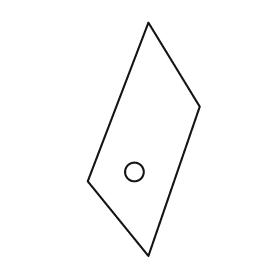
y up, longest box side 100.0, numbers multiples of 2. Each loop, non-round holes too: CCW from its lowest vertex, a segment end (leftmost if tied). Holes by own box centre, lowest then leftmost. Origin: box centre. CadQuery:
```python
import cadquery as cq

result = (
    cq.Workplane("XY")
    .moveTo(2.0, -50.0)
    .lineTo(24.0, 14.0)
    .lineTo(2.0, 50.0)
    .lineTo(-24.0, -18.0)
    .close()
    .moveTo(-4.0, -14.0)
    .circle(4.0)
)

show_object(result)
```